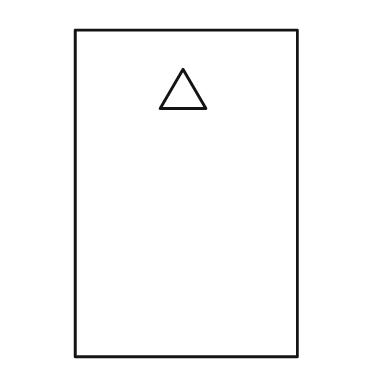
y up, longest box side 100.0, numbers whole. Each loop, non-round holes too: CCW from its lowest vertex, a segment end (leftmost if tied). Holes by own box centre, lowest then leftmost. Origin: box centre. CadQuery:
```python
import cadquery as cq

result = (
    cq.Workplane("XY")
    .moveTo(-34.0, -50.0)
    .lineTo(34.0, -50.0)
    .lineTo(34.0, 50.0)
    .lineTo(-34.0, 50.0)
    .close()
    .moveTo(-8.0, 26.0)
    .lineTo(6.0, 26.0)
    .lineTo(-1.0, 38.0)
    .close()
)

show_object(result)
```